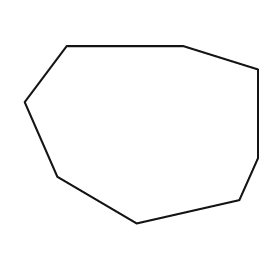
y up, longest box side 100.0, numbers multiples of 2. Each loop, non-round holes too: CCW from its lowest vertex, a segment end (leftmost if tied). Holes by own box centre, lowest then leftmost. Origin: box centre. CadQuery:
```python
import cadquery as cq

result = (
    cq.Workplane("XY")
    .moveTo(-2.0, -38.0)
    .lineTo(42.0, -28.0)
    .lineTo(50.0, -10.0)
    .lineTo(50.0, 28.0)
    .lineTo(18.0, 38.0)
    .lineTo(-32.0, 38.0)
    .lineTo(-50.0, 14.0)
    .lineTo(-36.0, -18.0)
    .close()
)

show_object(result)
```